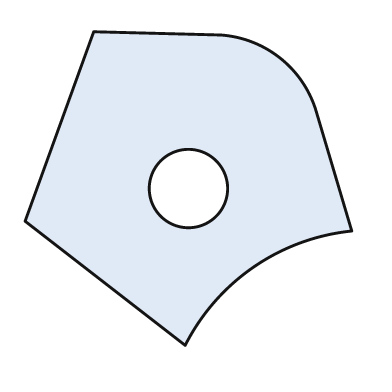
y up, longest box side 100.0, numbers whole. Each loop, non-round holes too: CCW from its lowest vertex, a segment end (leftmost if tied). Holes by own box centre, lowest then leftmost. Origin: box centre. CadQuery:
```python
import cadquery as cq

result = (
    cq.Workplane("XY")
    .moveTo(-1.0, -48.0)
    .threePointArc((20.0, -24.0), (50.0, -13.0))
    .lineTo(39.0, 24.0)
    .threePointArc((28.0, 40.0), (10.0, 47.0))
    .lineTo(-29.0, 48.0)
    .lineTo(-50.0, -10.0)
    .close()
    .moveTo(0.0, 0.0)
    .circle(12.0)
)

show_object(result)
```